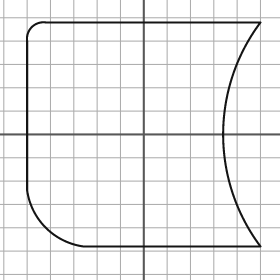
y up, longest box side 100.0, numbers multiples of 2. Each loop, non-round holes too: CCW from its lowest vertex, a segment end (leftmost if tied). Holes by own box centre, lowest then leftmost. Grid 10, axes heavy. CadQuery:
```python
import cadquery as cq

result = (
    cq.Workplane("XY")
    .moveTo(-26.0, -48.0)
    .lineTo(50.0, -48.0)
    .threePointArc((34.0, 0.0), (50.0, 48.0))
    .lineTo(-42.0, 48.0)
    .threePointArc((-48.0, 46.0), (-50.0, 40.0))
    .lineTo(-50.0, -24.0)
    .threePointArc((-42.0, -40.0), (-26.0, -48.0))
    .close()
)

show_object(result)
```